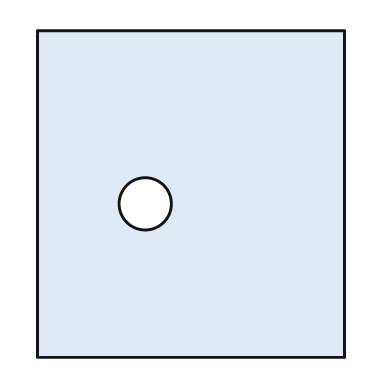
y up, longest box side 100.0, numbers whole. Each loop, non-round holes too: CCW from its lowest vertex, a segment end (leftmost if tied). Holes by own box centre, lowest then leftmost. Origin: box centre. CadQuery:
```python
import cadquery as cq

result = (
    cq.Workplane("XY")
    .moveTo(-47.0, -50.0)
    .lineTo(47.0, -50.0)
    .lineTo(47.0, 50.0)
    .lineTo(-47.0, 50.0)
    .close()
    .moveTo(-14.0, -3.0)
    .circle(8.0)
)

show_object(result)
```